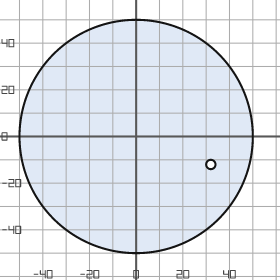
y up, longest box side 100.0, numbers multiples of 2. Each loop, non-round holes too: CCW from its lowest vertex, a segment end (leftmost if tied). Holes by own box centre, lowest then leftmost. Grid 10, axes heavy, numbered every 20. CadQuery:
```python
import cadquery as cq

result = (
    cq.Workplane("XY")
    .moveTo(0.0, 0.0)
    .circle(50.0)
    .moveTo(32.0, -12.0)
    .circle(2.0)
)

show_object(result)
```